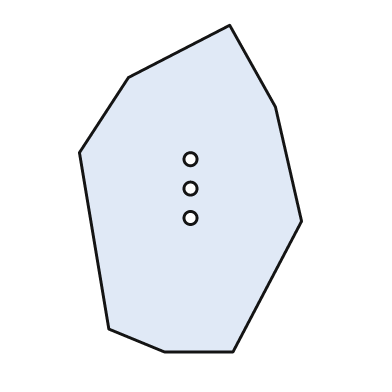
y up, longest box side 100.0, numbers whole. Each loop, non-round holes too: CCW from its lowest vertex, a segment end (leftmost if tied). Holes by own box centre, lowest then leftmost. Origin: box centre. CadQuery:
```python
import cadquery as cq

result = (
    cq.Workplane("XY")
    .moveTo(-8.0, -50.0)
    .lineTo(13.0, -50.0)
    .lineTo(34.0, -10.0)
    .lineTo(26.0, 25.0)
    .lineTo(12.0, 50.0)
    .lineTo(-19.0, 34.0)
    .lineTo(-34.0, 11.0)
    .lineTo(-25.0, -43.0)
    .close()
    .moveTo(0.0, -9.0)
    .circle(2.0)
    .moveTo(0.0, 0.0)
    .circle(2.0)
    .moveTo(0.0, 9.0)
    .circle(2.0)
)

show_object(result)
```